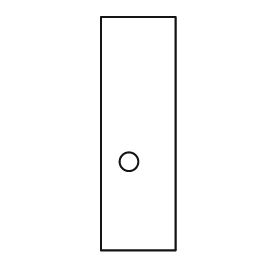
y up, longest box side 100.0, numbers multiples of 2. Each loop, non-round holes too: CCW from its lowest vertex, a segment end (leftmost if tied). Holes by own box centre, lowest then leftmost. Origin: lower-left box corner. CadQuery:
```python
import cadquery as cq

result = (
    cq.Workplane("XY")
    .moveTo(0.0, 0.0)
    .lineTo(32.0, 0.0)
    .lineTo(32.0, 100.0)
    .lineTo(0.0, 100.0)
    .close()
    .moveTo(12.0, 38.0)
    .circle(4.0)
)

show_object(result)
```